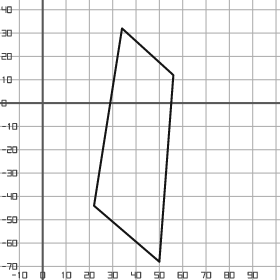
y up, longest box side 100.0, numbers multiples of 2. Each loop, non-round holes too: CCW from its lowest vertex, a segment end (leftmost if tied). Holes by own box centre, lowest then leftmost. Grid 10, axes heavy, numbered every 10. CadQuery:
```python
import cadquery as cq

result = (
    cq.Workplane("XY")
    .moveTo(50.0, -68.0)
    .lineTo(56.0, 12.0)
    .lineTo(34.0, 32.0)
    .lineTo(22.0, -44.0)
    .close()
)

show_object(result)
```